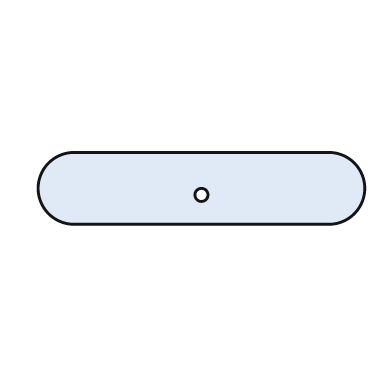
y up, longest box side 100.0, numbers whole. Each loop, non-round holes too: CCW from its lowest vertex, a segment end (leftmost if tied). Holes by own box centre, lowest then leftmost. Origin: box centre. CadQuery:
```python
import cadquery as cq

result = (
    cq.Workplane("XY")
    .moveTo(-39.0, -11.0)
    .lineTo(39.0, -11.0)
    .threePointArc((50.0, 0.0), (39.0, 11.0))
    .lineTo(-39.0, 11.0)
    .threePointArc((-50.0, 0.0), (-39.0, -11.0))
    .close()
    .moveTo(0.0, -2.0)
    .circle(2.0)
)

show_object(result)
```